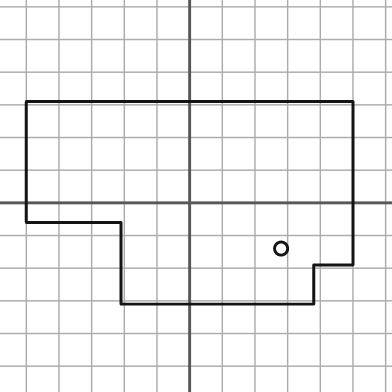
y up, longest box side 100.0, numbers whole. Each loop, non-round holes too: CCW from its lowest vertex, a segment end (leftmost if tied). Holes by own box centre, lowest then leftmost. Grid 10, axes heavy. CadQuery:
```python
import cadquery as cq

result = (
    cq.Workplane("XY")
    .moveTo(-21.0, -31.0)
    .lineTo(38.0, -31.0)
    .lineTo(38.0, -19.0)
    .lineTo(50.0, -19.0)
    .lineTo(50.0, 31.0)
    .lineTo(-50.0, 31.0)
    .lineTo(-50.0, -6.0)
    .lineTo(-21.0, -6.0)
    .close()
    .moveTo(28.0, -14.0)
    .circle(2.0)
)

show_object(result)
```